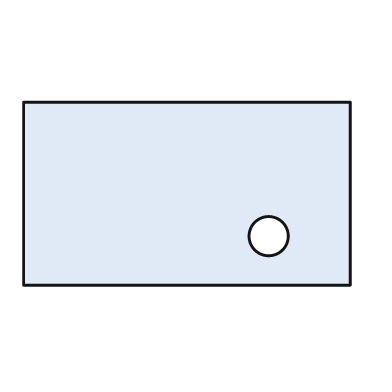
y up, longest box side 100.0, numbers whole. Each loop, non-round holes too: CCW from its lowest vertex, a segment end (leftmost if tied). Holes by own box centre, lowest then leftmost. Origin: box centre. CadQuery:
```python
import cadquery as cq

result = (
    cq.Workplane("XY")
    .moveTo(-50.0, -28.0)
    .lineTo(50.0, -28.0)
    .lineTo(50.0, 28.0)
    .lineTo(-50.0, 28.0)
    .close()
    .moveTo(25.0, -13.0)
    .circle(6.0)
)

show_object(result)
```